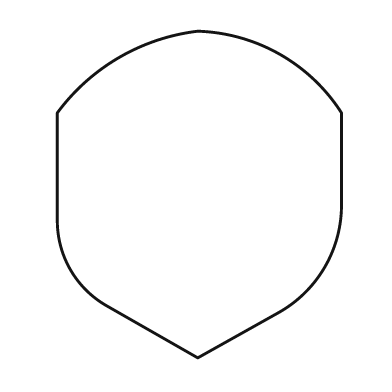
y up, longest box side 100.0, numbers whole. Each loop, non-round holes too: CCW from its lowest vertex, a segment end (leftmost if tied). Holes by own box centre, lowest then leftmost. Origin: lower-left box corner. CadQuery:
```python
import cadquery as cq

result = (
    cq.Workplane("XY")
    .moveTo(43.0, 0.0)
    .lineTo(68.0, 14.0)
    .threePointArc((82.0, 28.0), (87.0, 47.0))
    .lineTo(87.0, 75.0)
    .threePointArc((68.0, 93.0), (43.0, 100.0))
    .threePointArc((19.0, 92.0), (0.0, 75.0))
    .lineTo(0.0, 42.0)
    .threePointArc((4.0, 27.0), (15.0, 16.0))
    .close()
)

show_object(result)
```